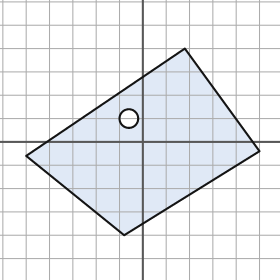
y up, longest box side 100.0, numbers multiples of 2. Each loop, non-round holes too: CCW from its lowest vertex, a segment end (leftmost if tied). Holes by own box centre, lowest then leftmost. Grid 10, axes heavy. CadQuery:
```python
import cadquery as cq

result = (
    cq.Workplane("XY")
    .moveTo(-8.0, -40.0)
    .lineTo(50.0, -4.0)
    .lineTo(18.0, 40.0)
    .lineTo(-50.0, -6.0)
    .close()
    .moveTo(-6.0, 10.0)
    .circle(4.0)
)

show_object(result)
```